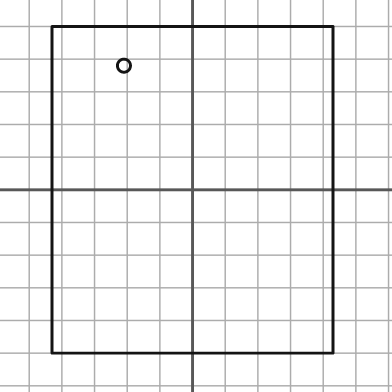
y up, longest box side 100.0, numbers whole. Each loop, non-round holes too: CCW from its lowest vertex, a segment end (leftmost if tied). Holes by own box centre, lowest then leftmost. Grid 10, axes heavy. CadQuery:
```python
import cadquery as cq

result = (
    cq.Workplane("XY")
    .moveTo(-43.0, -50.0)
    .lineTo(43.0, -50.0)
    .lineTo(43.0, 50.0)
    .lineTo(-43.0, 50.0)
    .close()
    .moveTo(-21.0, 38.0)
    .circle(2.0)
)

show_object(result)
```